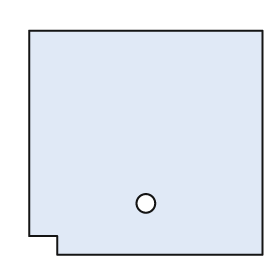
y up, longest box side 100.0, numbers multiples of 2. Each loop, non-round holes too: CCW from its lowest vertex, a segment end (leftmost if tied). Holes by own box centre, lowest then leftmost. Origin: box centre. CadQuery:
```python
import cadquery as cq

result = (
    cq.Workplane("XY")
    .moveTo(-38.0, -48.0)
    .lineTo(50.0, -48.0)
    .lineTo(50.0, 48.0)
    .lineTo(-50.0, 48.0)
    .lineTo(-50.0, -40.0)
    .lineTo(-38.0, -40.0)
    .close()
    .moveTo(0.0, -26.0)
    .circle(4.0)
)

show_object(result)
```